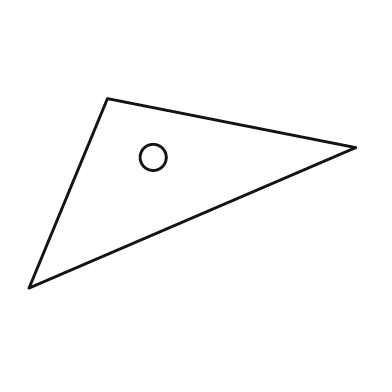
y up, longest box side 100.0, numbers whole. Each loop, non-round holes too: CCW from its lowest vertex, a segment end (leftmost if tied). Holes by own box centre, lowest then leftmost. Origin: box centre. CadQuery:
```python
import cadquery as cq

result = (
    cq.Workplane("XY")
    .moveTo(-50.0, -29.0)
    .lineTo(50.0, 14.0)
    .lineTo(-26.0, 29.0)
    .close()
    .moveTo(-12.0, 11.0)
    .circle(4.0)
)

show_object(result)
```